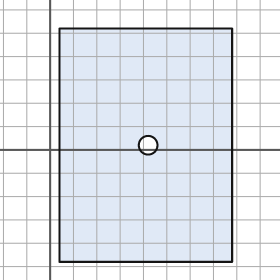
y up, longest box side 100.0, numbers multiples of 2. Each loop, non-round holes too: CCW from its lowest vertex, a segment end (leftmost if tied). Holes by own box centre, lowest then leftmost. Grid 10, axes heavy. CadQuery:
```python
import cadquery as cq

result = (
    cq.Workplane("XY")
    .moveTo(4.0, -48.0)
    .lineTo(78.0, -48.0)
    .lineTo(78.0, 52.0)
    .lineTo(4.0, 52.0)
    .close()
    .moveTo(42.0, 2.0)
    .circle(4.0)
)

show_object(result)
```